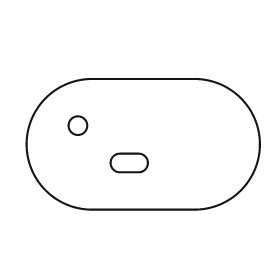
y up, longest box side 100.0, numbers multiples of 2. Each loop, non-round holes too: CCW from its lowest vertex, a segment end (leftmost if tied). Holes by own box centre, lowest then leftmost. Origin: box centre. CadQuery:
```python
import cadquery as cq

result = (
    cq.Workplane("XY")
    .moveTo(-22.0, -28.0)
    .lineTo(22.0, -28.0)
    .threePointArc((50.0, 0.0), (22.0, 28.0))
    .lineTo(-22.0, 28.0)
    .threePointArc((-50.0, 0.0), (-22.0, -28.0))
    .close()
    .moveTo(-10.0, -12.0)
    .lineTo(-2.0, -12.0)
    .threePointArc((2.0, -8.0), (-2.0, -4.0))
    .lineTo(-10.0, -4.0)
    .threePointArc((-14.0, -8.0), (-10.0, -12.0))
    .close()
    .moveTo(-28.0, 8.0)
    .circle(4.0)
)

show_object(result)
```